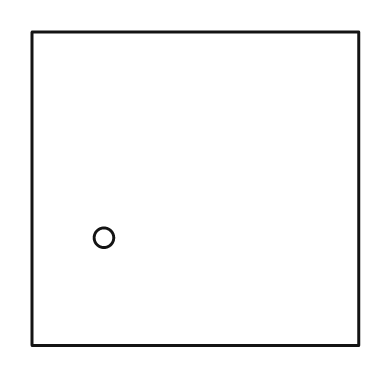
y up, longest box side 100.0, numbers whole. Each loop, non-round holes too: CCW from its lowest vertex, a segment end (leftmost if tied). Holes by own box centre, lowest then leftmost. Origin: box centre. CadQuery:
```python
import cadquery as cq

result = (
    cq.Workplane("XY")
    .moveTo(-50.0, -48.0)
    .lineTo(50.0, -48.0)
    .lineTo(50.0, 48.0)
    .lineTo(-50.0, 48.0)
    .close()
    .moveTo(-28.0, -15.0)
    .circle(3.0)
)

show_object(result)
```